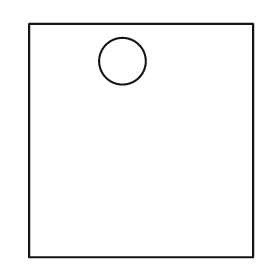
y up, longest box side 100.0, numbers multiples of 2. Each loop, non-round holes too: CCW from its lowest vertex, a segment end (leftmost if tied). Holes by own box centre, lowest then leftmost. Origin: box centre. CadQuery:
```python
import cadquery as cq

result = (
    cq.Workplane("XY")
    .moveTo(-48.0, -50.0)
    .lineTo(48.0, -50.0)
    .lineTo(48.0, 50.0)
    .lineTo(-48.0, 50.0)
    .close()
    .moveTo(-8.0, 34.0)
    .circle(10.0)
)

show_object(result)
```